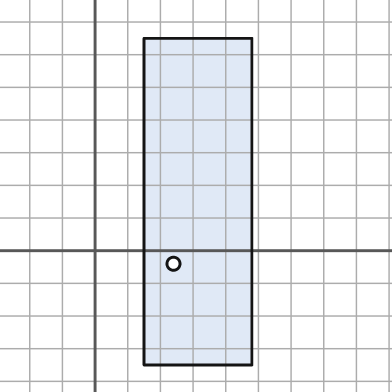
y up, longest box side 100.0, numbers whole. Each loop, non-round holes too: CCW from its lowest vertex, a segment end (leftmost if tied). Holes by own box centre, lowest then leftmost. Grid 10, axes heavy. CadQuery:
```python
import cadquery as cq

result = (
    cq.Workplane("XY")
    .moveTo(15.0, -35.0)
    .lineTo(48.0, -35.0)
    .lineTo(48.0, 65.0)
    .lineTo(15.0, 65.0)
    .close()
    .moveTo(24.0, -4.0)
    .circle(2.0)
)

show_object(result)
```